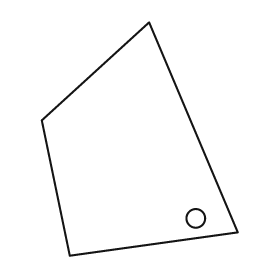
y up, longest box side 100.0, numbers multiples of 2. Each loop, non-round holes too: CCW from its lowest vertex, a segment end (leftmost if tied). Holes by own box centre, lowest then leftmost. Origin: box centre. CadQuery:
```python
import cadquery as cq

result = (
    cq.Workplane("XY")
    .moveTo(-30.0, -50.0)
    .lineTo(42.0, -40.0)
    .lineTo(4.0, 50.0)
    .lineTo(-42.0, 8.0)
    .close()
    .moveTo(24.0, -34.0)
    .circle(4.0)
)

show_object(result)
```